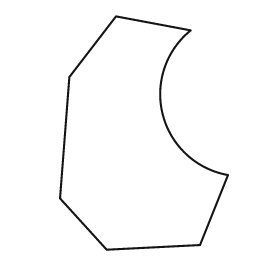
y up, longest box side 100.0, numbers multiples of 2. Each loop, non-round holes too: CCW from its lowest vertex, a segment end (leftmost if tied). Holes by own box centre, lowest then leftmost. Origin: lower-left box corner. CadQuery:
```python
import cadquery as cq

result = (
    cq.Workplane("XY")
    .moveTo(20.0, 0.0)
    .lineTo(60.0, 2.0)
    .lineTo(72.0, 32.0)
    .threePointArc((44.0, 58.0), (56.0, 94.0))
    .lineTo(24.0, 100.0)
    .lineTo(4.0, 74.0)
    .lineTo(0.0, 22.0)
    .close()
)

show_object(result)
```